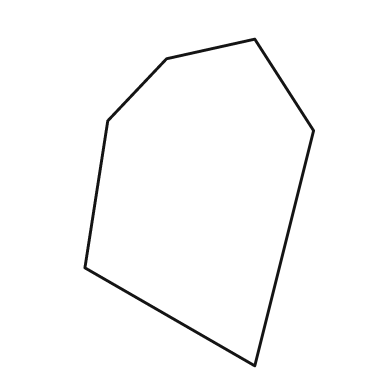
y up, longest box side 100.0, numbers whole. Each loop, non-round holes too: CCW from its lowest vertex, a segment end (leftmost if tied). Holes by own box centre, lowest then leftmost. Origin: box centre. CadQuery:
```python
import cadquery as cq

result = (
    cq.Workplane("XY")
    .moveTo(17.0, -50.0)
    .lineTo(35.0, 22.0)
    .lineTo(17.0, 50.0)
    .lineTo(-10.0, 44.0)
    .lineTo(-28.0, 25.0)
    .lineTo(-35.0, -20.0)
    .close()
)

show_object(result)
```